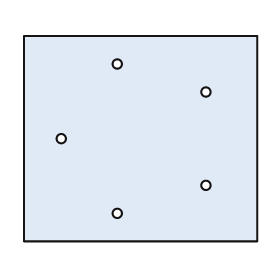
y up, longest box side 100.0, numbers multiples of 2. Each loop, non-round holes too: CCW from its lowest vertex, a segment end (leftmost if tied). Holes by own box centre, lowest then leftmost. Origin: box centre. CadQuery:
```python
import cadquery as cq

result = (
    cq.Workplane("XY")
    .moveTo(-50.0, -44.0)
    .lineTo(50.0, -44.0)
    .lineTo(50.0, 44.0)
    .lineTo(-50.0, 44.0)
    .close()
    .moveTo(-10.0, -32.0)
    .circle(2.0)
    .moveTo(28.0, -20.0)
    .circle(2.0)
    .moveTo(-34.0, 0.0)
    .circle(2.0)
    .moveTo(28.0, 20.0)
    .circle(2.0)
    .moveTo(-10.0, 32.0)
    .circle(2.0)
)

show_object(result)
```